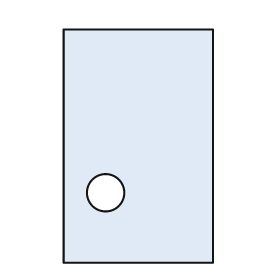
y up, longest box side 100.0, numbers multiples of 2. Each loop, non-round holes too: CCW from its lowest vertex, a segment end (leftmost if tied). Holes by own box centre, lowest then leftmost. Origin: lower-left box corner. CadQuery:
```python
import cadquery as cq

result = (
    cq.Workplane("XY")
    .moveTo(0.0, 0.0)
    .lineTo(64.0, 0.0)
    .lineTo(64.0, 100.0)
    .lineTo(0.0, 100.0)
    .close()
    .moveTo(18.0, 30.0)
    .circle(8.0)
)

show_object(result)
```